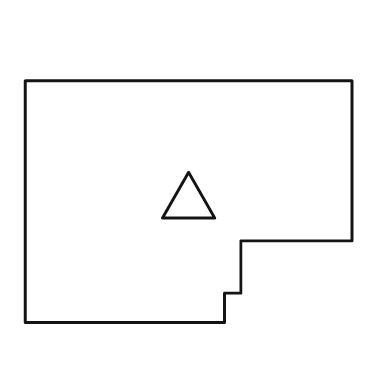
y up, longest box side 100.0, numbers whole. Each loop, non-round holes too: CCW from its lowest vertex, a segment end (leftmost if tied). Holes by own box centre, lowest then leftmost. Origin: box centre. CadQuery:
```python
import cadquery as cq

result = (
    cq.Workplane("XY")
    .moveTo(-50.0, -37.0)
    .lineTo(11.0, -37.0)
    .lineTo(11.0, -28.0)
    .lineTo(16.0, -28.0)
    .lineTo(16.0, -12.0)
    .lineTo(50.0, -12.0)
    .lineTo(50.0, 37.0)
    .lineTo(-50.0, 37.0)
    .close()
    .moveTo(-8.0, -5.0)
    .lineTo(8.0, -5.0)
    .lineTo(0.0, 9.0)
    .close()
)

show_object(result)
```